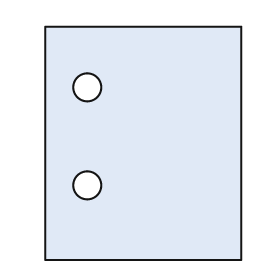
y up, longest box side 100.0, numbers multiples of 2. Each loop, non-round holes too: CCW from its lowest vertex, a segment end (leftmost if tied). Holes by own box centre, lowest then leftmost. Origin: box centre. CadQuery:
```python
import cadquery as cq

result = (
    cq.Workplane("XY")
    .moveTo(-42.0, -50.0)
    .lineTo(42.0, -50.0)
    .lineTo(42.0, 50.0)
    .lineTo(-42.0, 50.0)
    .close()
    .moveTo(-24.0, -18.0)
    .circle(6.0)
    .moveTo(-24.0, 24.0)
    .circle(6.0)
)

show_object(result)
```